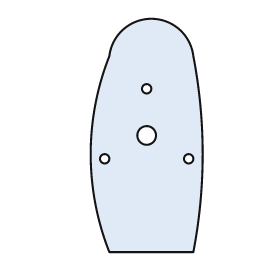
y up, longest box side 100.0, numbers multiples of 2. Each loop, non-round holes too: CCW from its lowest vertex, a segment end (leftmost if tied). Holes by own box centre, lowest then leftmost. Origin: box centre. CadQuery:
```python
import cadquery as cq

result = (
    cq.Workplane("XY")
    .moveTo(-16.0, -50.0)
    .lineTo(20.0, -50.0)
    .threePointArc((24.0, -8.0), (20.0, 34.0))
    .threePointArc((2.0, 50.0), (-16.0, 34.0))
    .threePointArc((-24.0, -8.0), (-16.0, -50.0))
    .close()
    .moveTo(-18.0, -10.0)
    .circle(2.0)
    .moveTo(18.0, -10.0)
    .circle(2.0)
    .moveTo(0.0, 0.0)
    .circle(4.0)
    .moveTo(0.0, 20.0)
    .circle(2.0)
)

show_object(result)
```